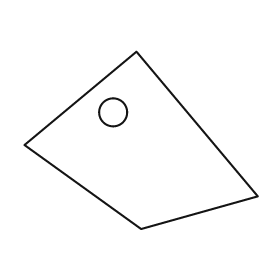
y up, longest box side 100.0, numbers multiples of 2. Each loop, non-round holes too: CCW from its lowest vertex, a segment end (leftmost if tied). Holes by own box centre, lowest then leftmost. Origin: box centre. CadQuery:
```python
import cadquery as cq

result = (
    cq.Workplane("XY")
    .moveTo(0.0, -38.0)
    .lineTo(50.0, -24.0)
    .lineTo(-2.0, 38.0)
    .lineTo(-50.0, -2.0)
    .close()
    .moveTo(-12.0, 12.0)
    .circle(6.0)
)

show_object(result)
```